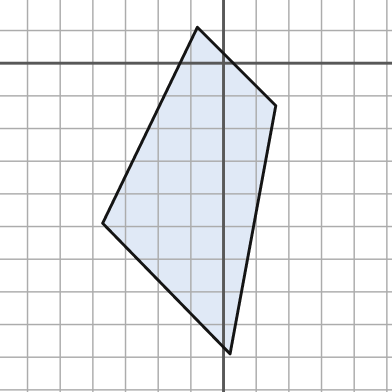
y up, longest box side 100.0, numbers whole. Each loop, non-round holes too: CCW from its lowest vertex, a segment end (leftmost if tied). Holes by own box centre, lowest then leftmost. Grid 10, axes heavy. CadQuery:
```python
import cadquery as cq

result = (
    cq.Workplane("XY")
    .moveTo(2.0, -89.0)
    .lineTo(16.0, -13.0)
    .lineTo(-8.0, 11.0)
    .lineTo(-37.0, -49.0)
    .close()
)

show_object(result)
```